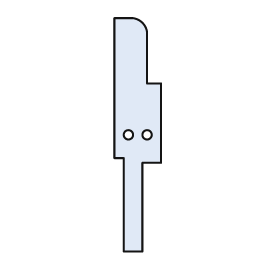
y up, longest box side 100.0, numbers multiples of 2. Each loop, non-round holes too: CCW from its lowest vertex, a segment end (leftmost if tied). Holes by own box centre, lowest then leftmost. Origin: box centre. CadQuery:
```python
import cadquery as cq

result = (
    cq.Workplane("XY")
    .moveTo(-6.0, -50.0)
    .lineTo(2.0, -50.0)
    .lineTo(2.0, -12.0)
    .lineTo(10.0, -12.0)
    .lineTo(10.0, 22.0)
    .lineTo(4.0, 22.0)
    .lineTo(4.0, 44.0)
    .threePointArc((2.0, 48.0), (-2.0, 50.0))
    .lineTo(-10.0, 50.0)
    .lineTo(-10.0, -10.0)
    .lineTo(-6.0, -10.0)
    .close()
    .moveTo(-4.0, 0.0)
    .circle(2.0)
    .moveTo(4.0, 0.0)
    .circle(2.0)
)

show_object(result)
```